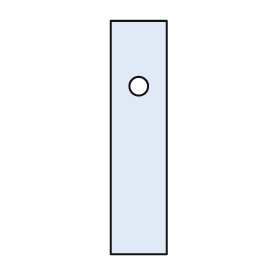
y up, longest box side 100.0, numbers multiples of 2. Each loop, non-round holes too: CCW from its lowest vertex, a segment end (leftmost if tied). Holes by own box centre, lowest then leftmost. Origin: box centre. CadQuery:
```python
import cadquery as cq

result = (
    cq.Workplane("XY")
    .moveTo(-12.0, -50.0)
    .lineTo(12.0, -50.0)
    .lineTo(12.0, 50.0)
    .lineTo(-12.0, 50.0)
    .close()
    .moveTo(0.0, 22.0)
    .circle(4.0)
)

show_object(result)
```